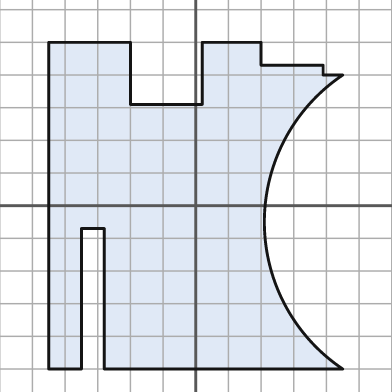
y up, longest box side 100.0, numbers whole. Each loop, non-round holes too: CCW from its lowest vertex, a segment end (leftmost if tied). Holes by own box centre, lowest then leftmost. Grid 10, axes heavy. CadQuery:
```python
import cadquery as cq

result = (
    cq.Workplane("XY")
    .moveTo(-45.0, -50.0)
    .lineTo(-35.0, -50.0)
    .lineTo(-35.0, -7.0)
    .lineTo(-28.0, -7.0)
    .lineTo(-28.0, -50.0)
    .lineTo(45.0, -50.0)
    .threePointArc((21.0, -5.0), (45.0, 40.0))
    .lineTo(39.0, 40.0)
    .lineTo(39.0, 43.0)
    .lineTo(20.0, 43.0)
    .lineTo(20.0, 50.0)
    .lineTo(2.0, 50.0)
    .lineTo(2.0, 31.0)
    .lineTo(-20.0, 31.0)
    .lineTo(-20.0, 50.0)
    .lineTo(-45.0, 50.0)
    .close()
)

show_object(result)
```